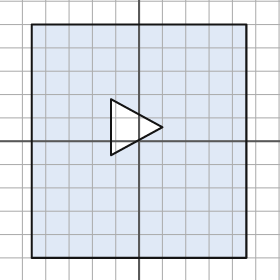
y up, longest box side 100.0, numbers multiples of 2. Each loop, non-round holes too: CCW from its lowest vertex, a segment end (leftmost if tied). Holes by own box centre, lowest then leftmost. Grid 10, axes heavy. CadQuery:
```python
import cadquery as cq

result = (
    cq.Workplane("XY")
    .moveTo(-46.0, -50.0)
    .lineTo(46.0, -50.0)
    .lineTo(46.0, 50.0)
    .lineTo(-46.0, 50.0)
    .close()
    .moveTo(-12.0, -6.0)
    .lineTo(10.0, 6.0)
    .lineTo(-12.0, 18.0)
    .close()
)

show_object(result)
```